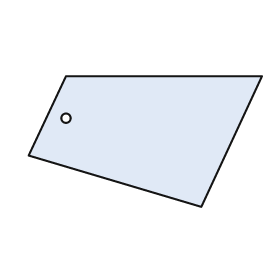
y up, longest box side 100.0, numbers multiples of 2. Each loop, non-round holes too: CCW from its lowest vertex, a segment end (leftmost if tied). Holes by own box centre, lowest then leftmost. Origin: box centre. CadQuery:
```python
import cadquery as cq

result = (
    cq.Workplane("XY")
    .moveTo(24.0, -28.0)
    .lineTo(50.0, 28.0)
    .lineTo(-34.0, 28.0)
    .lineTo(-50.0, -6.0)
    .close()
    .moveTo(-34.0, 10.0)
    .circle(2.0)
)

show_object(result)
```